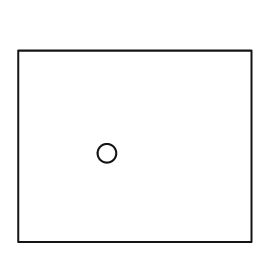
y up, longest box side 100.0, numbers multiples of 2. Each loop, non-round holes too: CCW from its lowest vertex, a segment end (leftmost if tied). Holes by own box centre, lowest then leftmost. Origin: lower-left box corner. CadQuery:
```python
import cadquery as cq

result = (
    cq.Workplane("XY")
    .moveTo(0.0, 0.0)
    .lineTo(100.0, 0.0)
    .lineTo(100.0, 82.0)
    .lineTo(0.0, 82.0)
    .close()
    .moveTo(38.0, 38.0)
    .circle(4.0)
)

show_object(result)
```